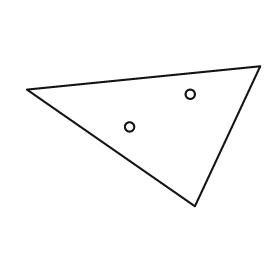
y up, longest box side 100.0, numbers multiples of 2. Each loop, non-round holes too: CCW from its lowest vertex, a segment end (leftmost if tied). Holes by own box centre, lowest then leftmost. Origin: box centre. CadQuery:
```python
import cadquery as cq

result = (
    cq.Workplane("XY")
    .moveTo(22.0, -30.0)
    .lineTo(50.0, 30.0)
    .lineTo(-50.0, 20.0)
    .close()
    .moveTo(-6.0, 4.0)
    .circle(2.0)
    .moveTo(20.0, 18.0)
    .circle(2.0)
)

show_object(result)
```